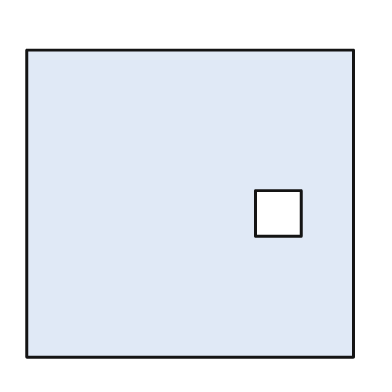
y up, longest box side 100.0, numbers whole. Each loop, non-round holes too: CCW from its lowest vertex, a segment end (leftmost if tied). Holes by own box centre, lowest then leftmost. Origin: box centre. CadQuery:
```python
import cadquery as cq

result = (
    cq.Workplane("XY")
    .moveTo(-50.0, -47.0)
    .lineTo(50.0, -47.0)
    .lineTo(50.0, 47.0)
    .lineTo(-50.0, 47.0)
    .close()
    .moveTo(20.0, -10.0)
    .lineTo(34.0, -10.0)
    .lineTo(34.0, 4.0)
    .lineTo(20.0, 4.0)
    .close()
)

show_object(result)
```